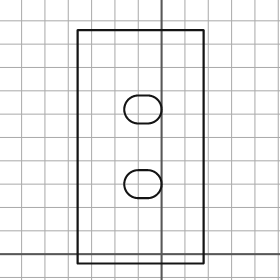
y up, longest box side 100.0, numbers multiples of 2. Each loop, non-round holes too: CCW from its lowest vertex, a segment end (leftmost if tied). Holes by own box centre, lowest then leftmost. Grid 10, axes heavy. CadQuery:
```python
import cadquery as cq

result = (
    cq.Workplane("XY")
    .moveTo(-36.0, -4.0)
    .lineTo(18.0, -4.0)
    .lineTo(18.0, 96.0)
    .lineTo(-36.0, 96.0)
    .close()
    .moveTo(-10.0, 24.0)
    .lineTo(-6.0, 24.0)
    .threePointArc((0.0, 30.0), (-6.0, 36.0))
    .lineTo(-10.0, 36.0)
    .threePointArc((-16.0, 30.0), (-10.0, 24.0))
    .close()
    .moveTo(-10.0, 56.0)
    .lineTo(-6.0, 56.0)
    .threePointArc((0.0, 62.0), (-6.0, 68.0))
    .lineTo(-10.0, 68.0)
    .threePointArc((-16.0, 62.0), (-10.0, 56.0))
    .close()
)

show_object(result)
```